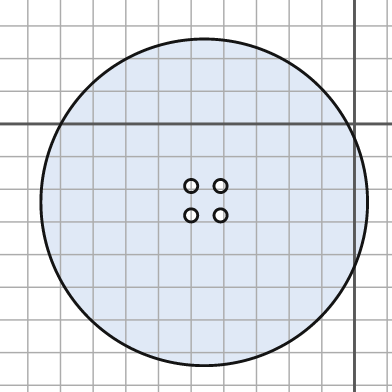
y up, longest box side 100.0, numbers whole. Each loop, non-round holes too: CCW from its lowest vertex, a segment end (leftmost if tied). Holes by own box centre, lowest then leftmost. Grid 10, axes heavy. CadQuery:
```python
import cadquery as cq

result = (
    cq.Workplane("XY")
    .moveTo(-46.0, -24.0)
    .circle(50.0)
    .moveTo(-50.0, -28.0)
    .circle(2.0)
    .moveTo(-41.0, -28.0)
    .circle(2.0)
    .moveTo(-50.0, -19.0)
    .circle(2.0)
    .moveTo(-41.0, -19.0)
    .circle(2.0)
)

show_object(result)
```